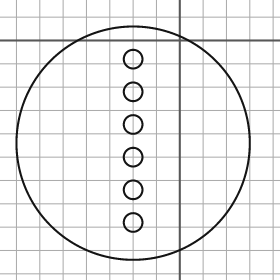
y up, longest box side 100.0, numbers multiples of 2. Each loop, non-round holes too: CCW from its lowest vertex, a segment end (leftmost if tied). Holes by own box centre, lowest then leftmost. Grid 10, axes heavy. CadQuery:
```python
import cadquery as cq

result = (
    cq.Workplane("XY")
    .moveTo(-20.0, -44.0)
    .circle(50.0)
    .moveTo(-20.0, -78.0)
    .circle(4.0)
    .moveTo(-20.0, -64.0)
    .circle(4.0)
    .moveTo(-20.0, -50.0)
    .circle(4.0)
    .moveTo(-20.0, -36.0)
    .circle(4.0)
    .moveTo(-20.0, -22.0)
    .circle(4.0)
    .moveTo(-20.0, -8.0)
    .circle(4.0)
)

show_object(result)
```